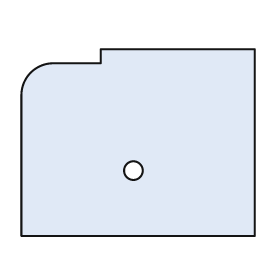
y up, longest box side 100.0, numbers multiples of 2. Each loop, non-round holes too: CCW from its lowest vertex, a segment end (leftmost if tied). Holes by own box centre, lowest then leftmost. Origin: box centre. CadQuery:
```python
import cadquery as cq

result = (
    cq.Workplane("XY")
    .moveTo(-50.0, -40.0)
    .lineTo(50.0, -40.0)
    .lineTo(50.0, 40.0)
    .lineTo(-16.0, 40.0)
    .lineTo(-16.0, 34.0)
    .lineTo(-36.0, 34.0)
    .threePointArc((-46.0, 30.0), (-50.0, 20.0))
    .close()
    .moveTo(-2.0, -12.0)
    .circle(4.0)
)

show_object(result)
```